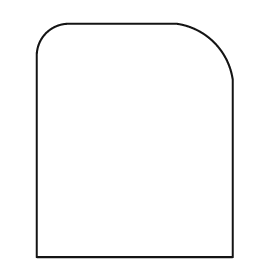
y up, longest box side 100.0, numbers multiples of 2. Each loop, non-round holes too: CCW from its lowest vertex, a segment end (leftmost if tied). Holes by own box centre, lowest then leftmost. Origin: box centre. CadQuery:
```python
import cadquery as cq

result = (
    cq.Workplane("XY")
    .moveTo(-42.0, -50.0)
    .lineTo(42.0, -50.0)
    .lineTo(42.0, 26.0)
    .threePointArc((34.0, 42.0), (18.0, 50.0))
    .lineTo(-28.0, 50.0)
    .threePointArc((-38.0, 46.0), (-42.0, 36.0))
    .close()
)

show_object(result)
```